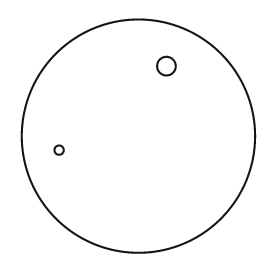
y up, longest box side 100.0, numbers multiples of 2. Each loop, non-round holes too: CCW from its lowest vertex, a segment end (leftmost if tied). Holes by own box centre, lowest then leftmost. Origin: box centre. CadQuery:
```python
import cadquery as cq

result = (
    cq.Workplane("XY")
    .moveTo(0.0, 0.0)
    .circle(50.0)
    .moveTo(-34.0, -6.0)
    .circle(2.0)
    .moveTo(12.0, 30.0)
    .circle(4.0)
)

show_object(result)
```